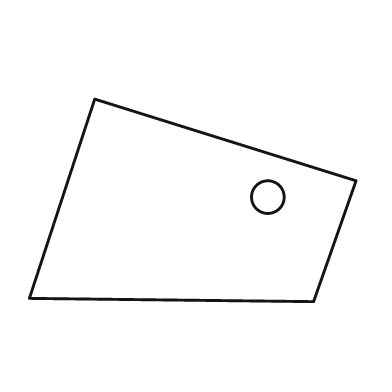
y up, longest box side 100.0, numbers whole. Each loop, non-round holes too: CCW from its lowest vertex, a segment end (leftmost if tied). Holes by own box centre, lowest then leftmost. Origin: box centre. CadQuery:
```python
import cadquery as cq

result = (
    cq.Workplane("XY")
    .moveTo(37.0, -31.0)
    .lineTo(50.0, 6.0)
    .lineTo(-30.0, 31.0)
    .lineTo(-50.0, -30.0)
    .close()
    .moveTo(23.0, 1.0)
    .circle(5.0)
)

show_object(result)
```